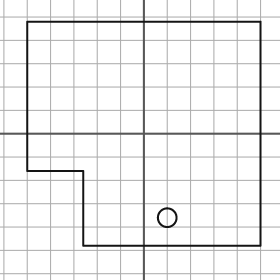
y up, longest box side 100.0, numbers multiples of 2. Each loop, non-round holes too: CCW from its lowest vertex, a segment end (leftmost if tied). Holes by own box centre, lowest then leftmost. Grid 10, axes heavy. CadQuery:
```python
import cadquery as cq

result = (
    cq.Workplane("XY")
    .moveTo(-26.0, -48.0)
    .lineTo(50.0, -48.0)
    .lineTo(50.0, 48.0)
    .lineTo(-50.0, 48.0)
    .lineTo(-50.0, -16.0)
    .lineTo(-26.0, -16.0)
    .close()
    .moveTo(10.0, -36.0)
    .circle(4.0)
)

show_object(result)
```